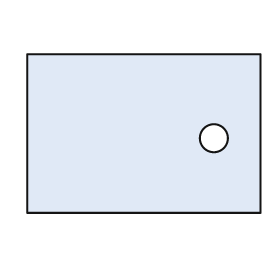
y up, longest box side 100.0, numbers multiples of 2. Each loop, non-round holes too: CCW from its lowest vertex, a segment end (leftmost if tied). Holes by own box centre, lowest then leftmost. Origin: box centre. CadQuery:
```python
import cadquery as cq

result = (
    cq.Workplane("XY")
    .moveTo(-50.0, -34.0)
    .lineTo(50.0, -34.0)
    .lineTo(50.0, 34.0)
    .lineTo(-50.0, 34.0)
    .close()
    .moveTo(30.0, -2.0)
    .circle(6.0)
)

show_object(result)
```